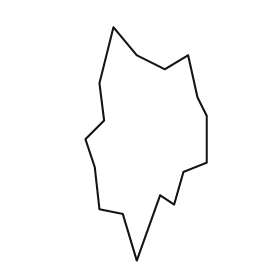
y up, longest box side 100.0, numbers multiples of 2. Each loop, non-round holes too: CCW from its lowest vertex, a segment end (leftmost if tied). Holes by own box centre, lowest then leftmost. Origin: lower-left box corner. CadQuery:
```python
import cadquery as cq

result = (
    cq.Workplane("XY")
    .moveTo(22.0, 0.0)
    .lineTo(32.0, 28.0)
    .lineTo(38.0, 24.0)
    .lineTo(42.0, 38.0)
    .lineTo(52.0, 42.0)
    .lineTo(52.0, 62.0)
    .lineTo(48.0, 70.0)
    .lineTo(44.0, 88.0)
    .lineTo(34.0, 82.0)
    .lineTo(22.0, 88.0)
    .lineTo(12.0, 100.0)
    .lineTo(6.0, 76.0)
    .lineTo(8.0, 60.0)
    .lineTo(0.0, 52.0)
    .lineTo(4.0, 40.0)
    .lineTo(6.0, 22.0)
    .lineTo(16.0, 20.0)
    .close()
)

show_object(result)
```